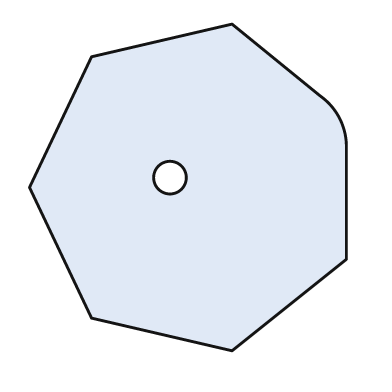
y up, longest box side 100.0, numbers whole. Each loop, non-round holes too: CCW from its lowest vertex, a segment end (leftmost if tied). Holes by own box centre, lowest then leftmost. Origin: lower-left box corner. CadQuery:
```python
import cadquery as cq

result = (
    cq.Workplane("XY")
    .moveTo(62.0, 0.0)
    .lineTo(97.0, 28.0)
    .lineTo(97.0, 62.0)
    .threePointArc((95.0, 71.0), (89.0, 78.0))
    .lineTo(62.0, 100.0)
    .lineTo(19.0, 90.0)
    .lineTo(0.0, 50.0)
    .lineTo(19.0, 10.0)
    .close()
    .moveTo(43.0, 53.0)
    .circle(5.0)
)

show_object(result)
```